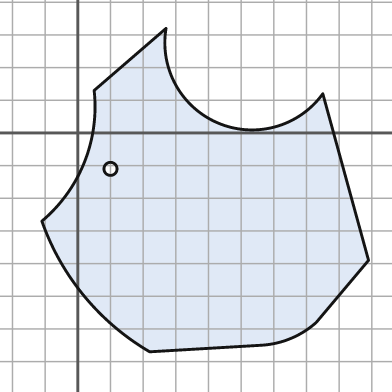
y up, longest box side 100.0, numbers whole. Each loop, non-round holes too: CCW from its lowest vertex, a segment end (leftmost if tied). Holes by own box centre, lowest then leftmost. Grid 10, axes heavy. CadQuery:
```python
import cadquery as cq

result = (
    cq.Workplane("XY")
    .moveTo(22.0, -67.0)
    .lineTo(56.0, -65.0)
    .threePointArc((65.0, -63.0), (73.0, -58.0))
    .lineTo(89.0, -39.0)
    .lineTo(75.0, 12.0)
    .threePointArc((43.0, 3.0), (27.0, 32.0))
    .lineTo(5.0, 13.0)
    .threePointArc((2.0, -9.0), (-11.0, -27.0))
    .threePointArc((2.0, -50.0), (22.0, -67.0))
    .close()
    .moveTo(10.0, -11.0)
    .circle(2.0)
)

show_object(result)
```